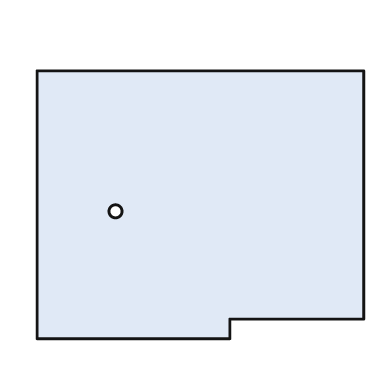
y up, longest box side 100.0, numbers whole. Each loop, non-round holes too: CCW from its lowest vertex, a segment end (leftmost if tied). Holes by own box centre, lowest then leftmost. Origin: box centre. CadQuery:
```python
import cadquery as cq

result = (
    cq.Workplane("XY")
    .moveTo(-50.0, -41.0)
    .lineTo(9.0, -41.0)
    .lineTo(9.0, -35.0)
    .lineTo(50.0, -35.0)
    .lineTo(50.0, 41.0)
    .lineTo(-50.0, 41.0)
    .close()
    .moveTo(-26.0, -2.0)
    .circle(2.0)
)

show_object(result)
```